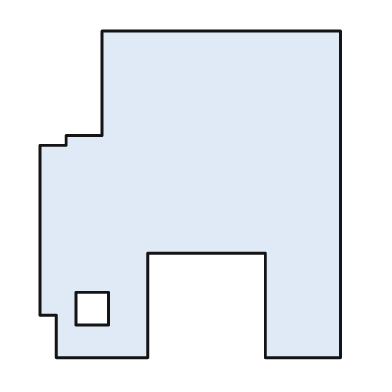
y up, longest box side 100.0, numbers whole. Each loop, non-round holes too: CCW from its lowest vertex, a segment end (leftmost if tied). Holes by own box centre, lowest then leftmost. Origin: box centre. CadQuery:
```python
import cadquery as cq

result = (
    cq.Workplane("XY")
    .moveTo(-41.0, -50.0)
    .lineTo(-13.0, -50.0)
    .lineTo(-13.0, -18.0)
    .lineTo(23.0, -18.0)
    .lineTo(23.0, -50.0)
    .lineTo(46.0, -50.0)
    .lineTo(46.0, 50.0)
    .lineTo(-27.0, 50.0)
    .lineTo(-27.0, 18.0)
    .lineTo(-38.0, 18.0)
    .lineTo(-38.0, 15.0)
    .lineTo(-46.0, 15.0)
    .lineTo(-46.0, -37.0)
    .lineTo(-41.0, -37.0)
    .close()
    .moveTo(-35.0, -40.0)
    .lineTo(-25.0, -40.0)
    .lineTo(-25.0, -30.0)
    .lineTo(-35.0, -30.0)
    .close()
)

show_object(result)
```